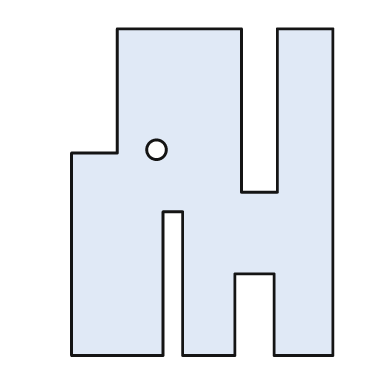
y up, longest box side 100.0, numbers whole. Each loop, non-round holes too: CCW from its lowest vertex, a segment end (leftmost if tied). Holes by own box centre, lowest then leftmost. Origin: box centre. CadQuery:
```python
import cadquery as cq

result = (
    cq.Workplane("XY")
    .moveTo(-40.0, -50.0)
    .lineTo(-12.0, -50.0)
    .lineTo(-12.0, -6.0)
    .lineTo(-6.0, -6.0)
    .lineTo(-6.0, -50.0)
    .lineTo(10.0, -50.0)
    .lineTo(10.0, -25.0)
    .lineTo(22.0, -25.0)
    .lineTo(22.0, -50.0)
    .lineTo(40.0, -50.0)
    .lineTo(40.0, 50.0)
    .lineTo(23.0, 50.0)
    .lineTo(23.0, 0.0)
    .lineTo(12.0, 0.0)
    .lineTo(12.0, 50.0)
    .lineTo(-26.0, 50.0)
    .lineTo(-26.0, 12.0)
    .lineTo(-40.0, 12.0)
    .close()
    .moveTo(-14.0, 13.0)
    .circle(3.0)
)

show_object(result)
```